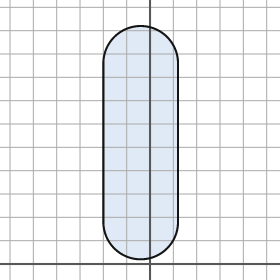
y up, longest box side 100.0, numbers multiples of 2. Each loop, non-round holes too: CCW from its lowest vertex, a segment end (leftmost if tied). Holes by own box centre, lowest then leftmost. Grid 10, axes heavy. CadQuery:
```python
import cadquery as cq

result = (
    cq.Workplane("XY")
    .moveTo(-20.0, 18.0)
    .threePointArc((-4.0, 2.0), (12.0, 18.0))
    .lineTo(12.0, 86.0)
    .threePointArc((-4.0, 102.0), (-20.0, 86.0))
    .close()
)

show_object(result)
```